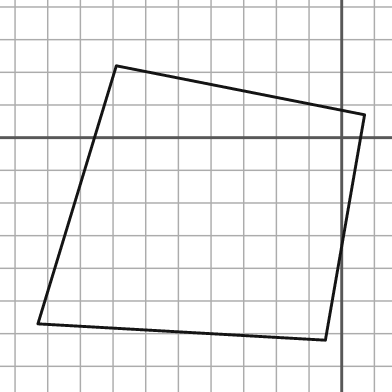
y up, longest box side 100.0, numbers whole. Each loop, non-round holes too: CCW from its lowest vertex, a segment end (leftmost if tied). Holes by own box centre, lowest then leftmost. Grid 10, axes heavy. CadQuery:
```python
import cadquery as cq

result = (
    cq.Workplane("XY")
    .moveTo(-5.0, -62.0)
    .lineTo(7.0, 7.0)
    .lineTo(-69.0, 22.0)
    .lineTo(-93.0, -57.0)
    .close()
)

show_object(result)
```